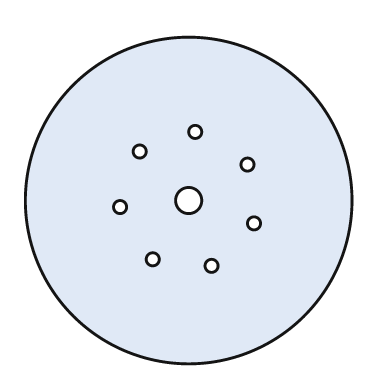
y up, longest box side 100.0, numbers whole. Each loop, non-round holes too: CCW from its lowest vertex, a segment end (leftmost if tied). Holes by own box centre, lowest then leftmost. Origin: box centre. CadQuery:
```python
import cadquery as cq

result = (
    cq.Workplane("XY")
    .moveTo(0.0, 0.0)
    .circle(50.0)
    .moveTo(7.0, -20.0)
    .circle(2.0)
    .moveTo(-11.0, -18.0)
    .circle(2.0)
    .moveTo(20.0, -7.0)
    .circle(2.0)
    .moveTo(-21.0, -2.0)
    .circle(2.0)
    .moveTo(0.0, 0.0)
    .circle(4.0)
    .moveTo(18.0, 11.0)
    .circle(2.0)
    .moveTo(-15.0, 15.0)
    .circle(2.0)
    .moveTo(2.0, 21.0)
    .circle(2.0)
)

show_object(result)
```